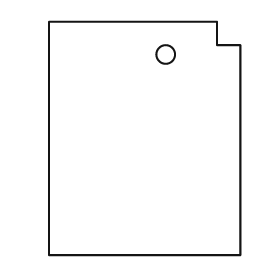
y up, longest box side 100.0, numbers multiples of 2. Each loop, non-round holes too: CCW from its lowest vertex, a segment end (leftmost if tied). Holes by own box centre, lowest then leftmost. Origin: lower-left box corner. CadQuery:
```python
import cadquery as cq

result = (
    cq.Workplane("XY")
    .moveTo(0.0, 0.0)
    .lineTo(82.0, 0.0)
    .lineTo(82.0, 90.0)
    .lineTo(72.0, 90.0)
    .lineTo(72.0, 100.0)
    .lineTo(0.0, 100.0)
    .close()
    .moveTo(50.0, 86.0)
    .circle(4.0)
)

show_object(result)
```